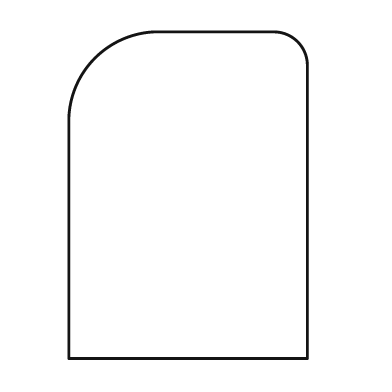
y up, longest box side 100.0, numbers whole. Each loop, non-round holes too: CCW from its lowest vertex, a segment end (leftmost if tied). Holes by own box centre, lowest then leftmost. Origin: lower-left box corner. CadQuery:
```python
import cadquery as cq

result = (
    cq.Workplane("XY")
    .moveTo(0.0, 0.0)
    .lineTo(73.0, 0.0)
    .lineTo(73.0, 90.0)
    .threePointArc((70.0, 97.0), (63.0, 100.0))
    .lineTo(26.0, 100.0)
    .threePointArc((8.0, 92.0), (0.0, 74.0))
    .close()
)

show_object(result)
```